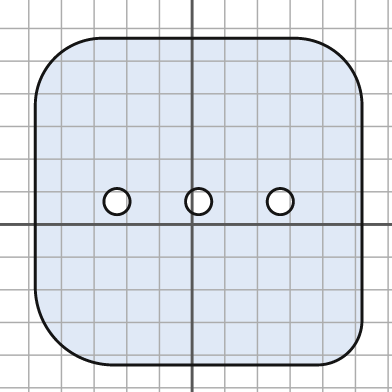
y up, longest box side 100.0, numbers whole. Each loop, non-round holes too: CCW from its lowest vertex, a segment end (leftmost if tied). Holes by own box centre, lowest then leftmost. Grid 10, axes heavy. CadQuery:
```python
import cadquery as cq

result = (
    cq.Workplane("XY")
    .moveTo(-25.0, -43.0)
    .lineTo(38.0, -43.0)
    .threePointArc((48.0, -39.0), (52.0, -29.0))
    .lineTo(52.0, 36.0)
    .threePointArc((46.0, 51.0), (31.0, 57.0))
    .lineTo(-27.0, 57.0)
    .threePointArc((-42.0, 51.0), (-48.0, 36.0))
    .lineTo(-48.0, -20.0)
    .threePointArc((-41.0, -36.0), (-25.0, -43.0))
    .close()
    .moveTo(-23.0, 7.0)
    .circle(4.0)
    .moveTo(2.0, 7.0)
    .circle(4.0)
    .moveTo(27.0, 7.0)
    .circle(4.0)
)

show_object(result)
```